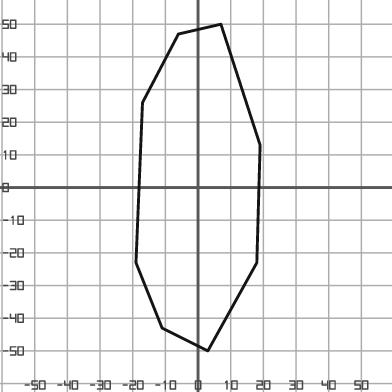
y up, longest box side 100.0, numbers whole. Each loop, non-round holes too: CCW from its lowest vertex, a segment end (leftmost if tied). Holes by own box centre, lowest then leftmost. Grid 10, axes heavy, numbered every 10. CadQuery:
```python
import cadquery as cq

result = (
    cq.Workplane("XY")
    .moveTo(3.0, -50.0)
    .lineTo(18.0, -23.0)
    .lineTo(19.0, 13.0)
    .lineTo(7.0, 50.0)
    .lineTo(-6.0, 47.0)
    .lineTo(-17.0, 26.0)
    .lineTo(-19.0, -23.0)
    .lineTo(-11.0, -43.0)
    .close()
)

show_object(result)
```